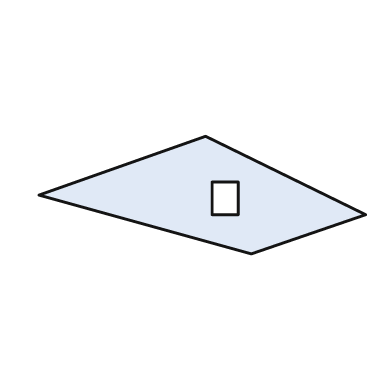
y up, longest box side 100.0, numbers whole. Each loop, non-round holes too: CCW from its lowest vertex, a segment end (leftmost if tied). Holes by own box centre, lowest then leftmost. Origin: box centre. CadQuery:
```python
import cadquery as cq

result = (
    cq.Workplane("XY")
    .moveTo(15.0, -18.0)
    .lineTo(50.0, -6.0)
    .lineTo(1.0, 18.0)
    .lineTo(-50.0, 0.0)
    .close()
    .moveTo(3.0, -6.0)
    .lineTo(11.0, -6.0)
    .lineTo(11.0, 4.0)
    .lineTo(3.0, 4.0)
    .close()
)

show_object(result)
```